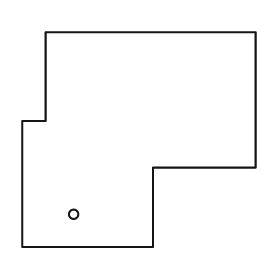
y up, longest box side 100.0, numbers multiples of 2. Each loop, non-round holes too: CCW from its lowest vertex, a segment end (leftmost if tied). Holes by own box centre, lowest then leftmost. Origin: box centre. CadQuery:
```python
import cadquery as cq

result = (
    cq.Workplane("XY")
    .moveTo(-50.0, -46.0)
    .lineTo(6.0, -46.0)
    .lineTo(6.0, -12.0)
    .lineTo(50.0, -12.0)
    .lineTo(50.0, 46.0)
    .lineTo(-40.0, 46.0)
    .lineTo(-40.0, 8.0)
    .lineTo(-50.0, 8.0)
    .close()
    .moveTo(-28.0, -32.0)
    .circle(2.0)
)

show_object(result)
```